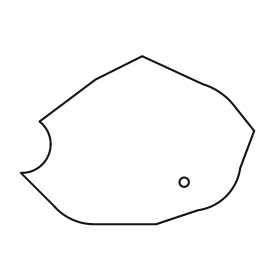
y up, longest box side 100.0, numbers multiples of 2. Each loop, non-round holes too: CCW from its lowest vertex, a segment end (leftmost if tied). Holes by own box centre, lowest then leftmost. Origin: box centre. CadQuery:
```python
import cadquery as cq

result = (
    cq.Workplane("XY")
    .moveTo(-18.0, -36.0)
    .lineTo(8.0, -36.0)
    .lineTo(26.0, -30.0)
    .threePointArc((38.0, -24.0), (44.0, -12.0))
    .lineTo(50.0, 4.0)
    .lineTo(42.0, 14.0)
    .threePointArc((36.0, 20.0), (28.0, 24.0))
    .lineTo(2.0, 36.0)
    .lineTo(-18.0, 26.0)
    .lineTo(-42.0, 8.0)
    .threePointArc((-38.0, -6.0), (-50.0, -14.0))
    .lineTo(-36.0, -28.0)
    .threePointArc((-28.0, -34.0), (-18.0, -36.0))
    .close()
    .moveTo(20.0, -18.0)
    .circle(2.0)
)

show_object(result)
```